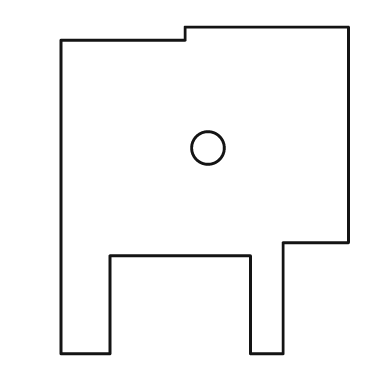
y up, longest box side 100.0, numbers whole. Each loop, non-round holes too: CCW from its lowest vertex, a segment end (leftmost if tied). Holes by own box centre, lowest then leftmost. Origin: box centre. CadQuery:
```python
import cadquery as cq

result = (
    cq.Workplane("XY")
    .moveTo(-44.0, -50.0)
    .lineTo(-29.0, -50.0)
    .lineTo(-29.0, -20.0)
    .lineTo(14.0, -20.0)
    .lineTo(14.0, -50.0)
    .lineTo(24.0, -50.0)
    .lineTo(24.0, -16.0)
    .lineTo(44.0, -16.0)
    .lineTo(44.0, 50.0)
    .lineTo(-6.0, 50.0)
    .lineTo(-6.0, 46.0)
    .lineTo(-44.0, 46.0)
    .close()
    .moveTo(1.0, 13.0)
    .circle(5.0)
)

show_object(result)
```